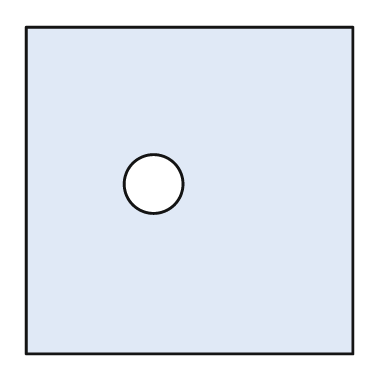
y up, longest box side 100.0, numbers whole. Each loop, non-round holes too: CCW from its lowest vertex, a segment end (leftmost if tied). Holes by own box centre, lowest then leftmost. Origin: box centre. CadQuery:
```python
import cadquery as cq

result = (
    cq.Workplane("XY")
    .moveTo(-50.0, -50.0)
    .lineTo(50.0, -50.0)
    .lineTo(50.0, 50.0)
    .lineTo(-50.0, 50.0)
    .close()
    .moveTo(-11.0, 2.0)
    .circle(9.0)
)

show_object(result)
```